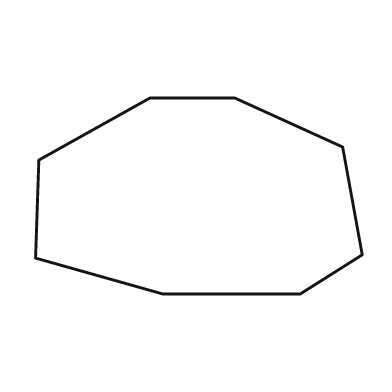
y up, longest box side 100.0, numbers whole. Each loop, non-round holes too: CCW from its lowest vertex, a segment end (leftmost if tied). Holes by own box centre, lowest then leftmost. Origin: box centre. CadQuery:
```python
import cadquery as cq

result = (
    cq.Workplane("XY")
    .moveTo(-11.0, -30.0)
    .lineTo(31.0, -30.0)
    .lineTo(50.0, -18.0)
    .lineTo(44.0, 15.0)
    .lineTo(11.0, 30.0)
    .lineTo(-15.0, 30.0)
    .lineTo(-49.0, 11.0)
    .lineTo(-50.0, -19.0)
    .close()
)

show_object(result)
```